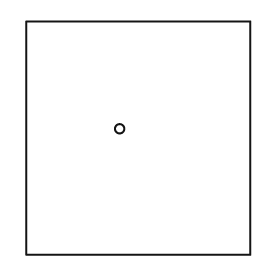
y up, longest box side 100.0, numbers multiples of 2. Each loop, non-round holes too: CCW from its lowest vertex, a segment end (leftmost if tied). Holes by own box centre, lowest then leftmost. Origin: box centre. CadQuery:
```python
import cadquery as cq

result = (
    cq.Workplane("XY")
    .moveTo(-48.0, -50.0)
    .lineTo(48.0, -50.0)
    .lineTo(48.0, 50.0)
    .lineTo(-48.0, 50.0)
    .close()
    .moveTo(-8.0, 4.0)
    .circle(2.0)
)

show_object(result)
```